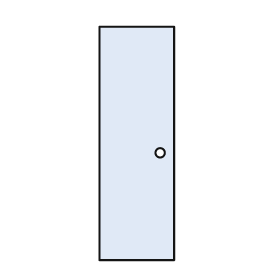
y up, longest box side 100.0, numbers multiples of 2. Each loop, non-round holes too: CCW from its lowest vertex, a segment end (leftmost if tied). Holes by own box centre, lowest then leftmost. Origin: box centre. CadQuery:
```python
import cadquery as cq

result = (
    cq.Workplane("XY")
    .moveTo(-16.0, -50.0)
    .lineTo(16.0, -50.0)
    .lineTo(16.0, 50.0)
    .lineTo(-16.0, 50.0)
    .close()
    .moveTo(10.0, -4.0)
    .circle(2.0)
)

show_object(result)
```